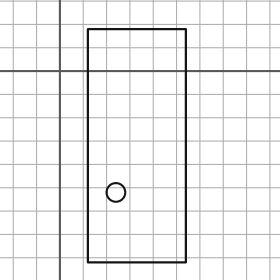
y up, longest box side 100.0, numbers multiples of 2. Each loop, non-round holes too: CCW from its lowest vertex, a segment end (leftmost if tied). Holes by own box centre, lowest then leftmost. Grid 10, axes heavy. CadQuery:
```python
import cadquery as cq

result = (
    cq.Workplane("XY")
    .moveTo(12.0, -82.0)
    .lineTo(54.0, -82.0)
    .lineTo(54.0, 18.0)
    .lineTo(12.0, 18.0)
    .close()
    .moveTo(24.0, -52.0)
    .circle(4.0)
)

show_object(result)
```